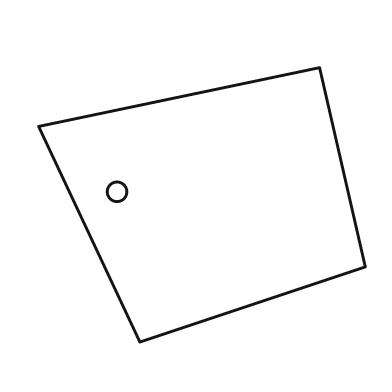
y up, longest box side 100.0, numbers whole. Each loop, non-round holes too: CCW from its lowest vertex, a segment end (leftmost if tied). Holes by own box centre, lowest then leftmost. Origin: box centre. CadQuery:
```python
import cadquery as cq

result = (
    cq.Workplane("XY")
    .moveTo(-19.0, -42.0)
    .lineTo(50.0, -19.0)
    .lineTo(36.0, 42.0)
    .lineTo(-50.0, 24.0)
    .close()
    .moveTo(-26.0, 4.0)
    .circle(3.0)
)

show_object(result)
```